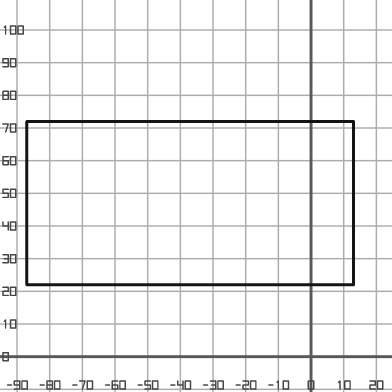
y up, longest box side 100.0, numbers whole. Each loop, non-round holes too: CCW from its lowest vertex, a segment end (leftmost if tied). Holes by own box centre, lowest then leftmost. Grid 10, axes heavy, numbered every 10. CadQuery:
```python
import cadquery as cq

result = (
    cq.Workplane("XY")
    .moveTo(-87.0, 22.0)
    .lineTo(13.0, 22.0)
    .lineTo(13.0, 72.0)
    .lineTo(-87.0, 72.0)
    .close()
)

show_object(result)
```